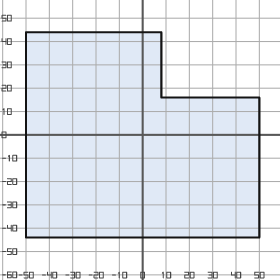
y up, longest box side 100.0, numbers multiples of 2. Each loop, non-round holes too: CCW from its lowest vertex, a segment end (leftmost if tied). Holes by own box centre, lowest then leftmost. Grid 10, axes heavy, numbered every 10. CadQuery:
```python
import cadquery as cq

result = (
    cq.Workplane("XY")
    .moveTo(-50.0, -44.0)
    .lineTo(50.0, -44.0)
    .lineTo(50.0, 16.0)
    .lineTo(8.0, 16.0)
    .lineTo(8.0, 44.0)
    .lineTo(-50.0, 44.0)
    .close()
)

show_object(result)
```